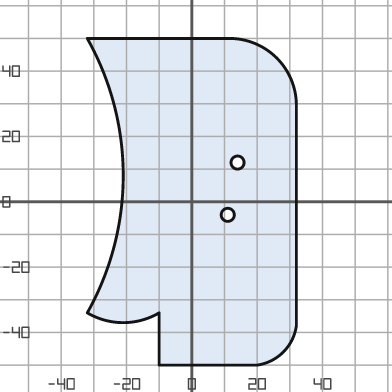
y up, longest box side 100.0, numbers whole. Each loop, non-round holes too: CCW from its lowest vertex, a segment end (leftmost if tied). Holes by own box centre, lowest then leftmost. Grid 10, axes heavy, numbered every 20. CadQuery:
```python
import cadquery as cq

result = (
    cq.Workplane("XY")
    .moveTo(-10.0, -50.0)
    .lineTo(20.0, -50.0)
    .threePointArc((28.0, -46.0), (32.0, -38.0))
    .lineTo(32.0, 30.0)
    .threePointArc((26.0, 44.0), (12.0, 50.0))
    .lineTo(-32.0, 50.0)
    .threePointArc((-21.0, 8.0), (-32.0, -34.0))
    .threePointArc((-21.0, -37.0), (-10.0, -34.0))
    .close()
    .moveTo(11.0, -4.0)
    .circle(2.0)
    .moveTo(14.0, 12.0)
    .circle(2.0)
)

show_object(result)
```